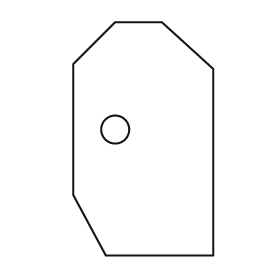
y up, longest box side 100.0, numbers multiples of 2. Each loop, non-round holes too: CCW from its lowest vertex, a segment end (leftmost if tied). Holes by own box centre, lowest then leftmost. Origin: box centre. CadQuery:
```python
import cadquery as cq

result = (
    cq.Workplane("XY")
    .moveTo(-16.0, -50.0)
    .lineTo(30.0, -50.0)
    .lineTo(30.0, 30.0)
    .lineTo(8.0, 50.0)
    .lineTo(-12.0, 50.0)
    .lineTo(-30.0, 32.0)
    .lineTo(-30.0, -24.0)
    .close()
    .moveTo(-12.0, 4.0)
    .circle(6.0)
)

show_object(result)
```